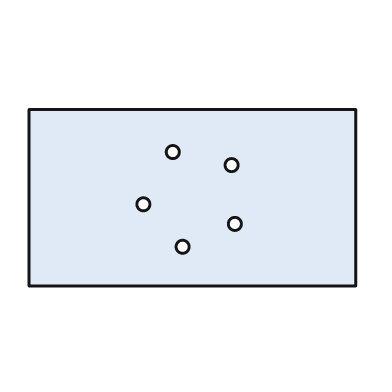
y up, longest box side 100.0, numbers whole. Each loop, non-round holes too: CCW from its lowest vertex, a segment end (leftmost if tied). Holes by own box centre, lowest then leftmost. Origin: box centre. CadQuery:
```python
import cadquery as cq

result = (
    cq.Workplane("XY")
    .moveTo(-50.0, -27.0)
    .lineTo(50.0, -27.0)
    .lineTo(50.0, 27.0)
    .lineTo(-50.0, 27.0)
    .close()
    .moveTo(-3.0, -15.0)
    .circle(2.0)
    .moveTo(13.0, -8.0)
    .circle(2.0)
    .moveTo(-15.0, -2.0)
    .circle(2.0)
    .moveTo(12.0, 10.0)
    .circle(2.0)
    .moveTo(-6.0, 14.0)
    .circle(2.0)
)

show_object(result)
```